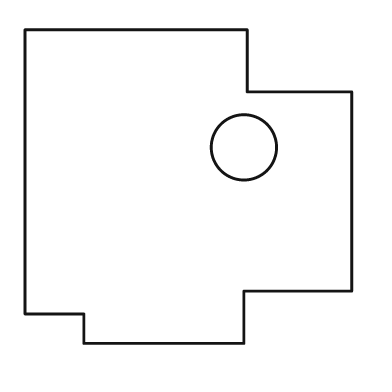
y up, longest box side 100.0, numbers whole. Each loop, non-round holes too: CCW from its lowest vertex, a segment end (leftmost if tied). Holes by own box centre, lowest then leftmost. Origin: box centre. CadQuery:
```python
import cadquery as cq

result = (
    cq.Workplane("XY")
    .moveTo(-32.0, -48.0)
    .lineTo(17.0, -48.0)
    .lineTo(17.0, -32.0)
    .lineTo(50.0, -32.0)
    .lineTo(50.0, 29.0)
    .lineTo(18.0, 29.0)
    .lineTo(18.0, 48.0)
    .lineTo(-50.0, 48.0)
    .lineTo(-50.0, -39.0)
    .lineTo(-32.0, -39.0)
    .close()
    .moveTo(17.0, 12.0)
    .circle(10.0)
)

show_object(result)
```